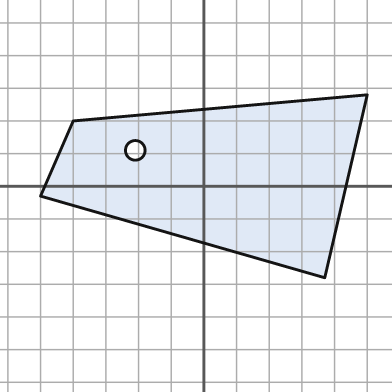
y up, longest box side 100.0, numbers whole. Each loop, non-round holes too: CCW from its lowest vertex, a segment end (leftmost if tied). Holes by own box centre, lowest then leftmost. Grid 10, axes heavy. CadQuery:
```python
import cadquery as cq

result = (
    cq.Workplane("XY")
    .moveTo(37.0, -28.0)
    .lineTo(50.0, 28.0)
    .lineTo(-40.0, 20.0)
    .lineTo(-50.0, -3.0)
    .close()
    .moveTo(-21.0, 11.0)
    .circle(3.0)
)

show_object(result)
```